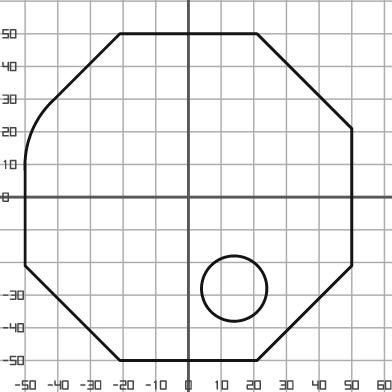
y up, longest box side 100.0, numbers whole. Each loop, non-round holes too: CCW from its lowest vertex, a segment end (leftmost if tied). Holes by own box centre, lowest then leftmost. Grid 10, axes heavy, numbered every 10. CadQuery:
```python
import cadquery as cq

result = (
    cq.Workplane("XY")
    .moveTo(-21.0, -50.0)
    .lineTo(21.0, -50.0)
    .lineTo(50.0, -21.0)
    .lineTo(50.0, 21.0)
    .lineTo(21.0, 50.0)
    .lineTo(-21.0, 50.0)
    .lineTo(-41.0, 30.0)
    .threePointArc((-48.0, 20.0), (-50.0, 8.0))
    .lineTo(-50.0, -21.0)
    .close()
    .moveTo(14.0, -28.0)
    .circle(10.0)
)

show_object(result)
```